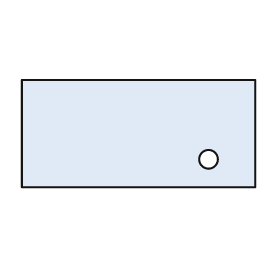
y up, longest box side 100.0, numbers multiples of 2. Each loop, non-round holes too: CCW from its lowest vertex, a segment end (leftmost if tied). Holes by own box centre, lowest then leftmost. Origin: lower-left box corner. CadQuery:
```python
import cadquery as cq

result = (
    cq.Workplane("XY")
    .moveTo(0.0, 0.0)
    .lineTo(100.0, 0.0)
    .lineTo(100.0, 46.0)
    .lineTo(0.0, 46.0)
    .close()
    .moveTo(80.0, 12.0)
    .circle(4.0)
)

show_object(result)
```